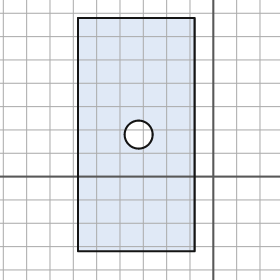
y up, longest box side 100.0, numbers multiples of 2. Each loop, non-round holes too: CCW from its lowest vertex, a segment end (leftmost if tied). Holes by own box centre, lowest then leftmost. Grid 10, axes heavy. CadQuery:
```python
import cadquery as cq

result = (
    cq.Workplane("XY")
    .moveTo(-58.0, -32.0)
    .lineTo(-8.0, -32.0)
    .lineTo(-8.0, 68.0)
    .lineTo(-58.0, 68.0)
    .close()
    .moveTo(-32.0, 18.0)
    .circle(6.0)
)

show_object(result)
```